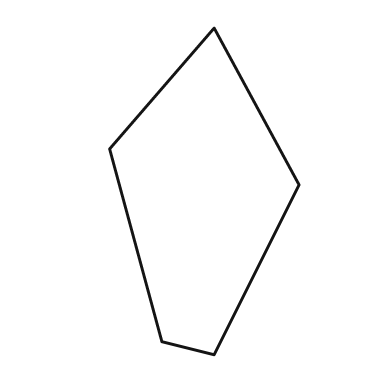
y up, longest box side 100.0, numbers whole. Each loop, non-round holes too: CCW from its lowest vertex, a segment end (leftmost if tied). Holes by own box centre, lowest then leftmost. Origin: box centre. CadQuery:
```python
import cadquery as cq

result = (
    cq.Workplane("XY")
    .moveTo(3.0, -50.0)
    .lineTo(29.0, 2.0)
    .lineTo(3.0, 50.0)
    .lineTo(-29.0, 13.0)
    .lineTo(-13.0, -46.0)
    .close()
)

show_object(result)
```